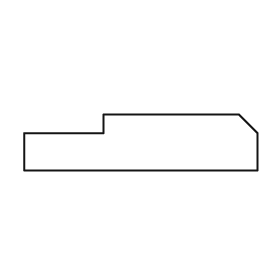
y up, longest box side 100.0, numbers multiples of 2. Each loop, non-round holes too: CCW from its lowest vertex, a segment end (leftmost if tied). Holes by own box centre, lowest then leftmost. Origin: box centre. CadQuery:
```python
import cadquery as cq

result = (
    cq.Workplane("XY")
    .moveTo(-50.0, -12.0)
    .lineTo(50.0, -12.0)
    .lineTo(50.0, 4.0)
    .lineTo(42.0, 12.0)
    .lineTo(-16.0, 12.0)
    .lineTo(-16.0, 4.0)
    .lineTo(-50.0, 4.0)
    .close()
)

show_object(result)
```